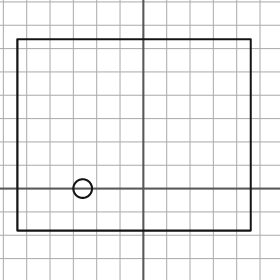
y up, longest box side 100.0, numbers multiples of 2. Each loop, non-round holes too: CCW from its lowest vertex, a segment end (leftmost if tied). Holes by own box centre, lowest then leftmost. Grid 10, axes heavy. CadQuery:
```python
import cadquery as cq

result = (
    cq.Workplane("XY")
    .moveTo(-54.0, -18.0)
    .lineTo(46.0, -18.0)
    .lineTo(46.0, 64.0)
    .lineTo(-54.0, 64.0)
    .close()
    .moveTo(-26.0, 0.0)
    .circle(4.0)
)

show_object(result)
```